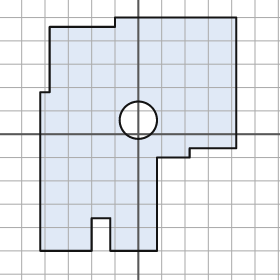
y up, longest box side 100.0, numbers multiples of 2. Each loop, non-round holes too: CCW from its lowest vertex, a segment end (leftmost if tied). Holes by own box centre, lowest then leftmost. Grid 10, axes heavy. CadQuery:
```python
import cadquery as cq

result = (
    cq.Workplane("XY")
    .moveTo(-42.0, -50.0)
    .lineTo(-20.0, -50.0)
    .lineTo(-20.0, -36.0)
    .lineTo(-12.0, -36.0)
    .lineTo(-12.0, -50.0)
    .lineTo(8.0, -50.0)
    .lineTo(8.0, -10.0)
    .lineTo(22.0, -10.0)
    .lineTo(22.0, -6.0)
    .lineTo(42.0, -6.0)
    .lineTo(42.0, 50.0)
    .lineTo(-10.0, 50.0)
    .lineTo(-10.0, 46.0)
    .lineTo(-38.0, 46.0)
    .lineTo(-38.0, 18.0)
    .lineTo(-42.0, 18.0)
    .close()
    .moveTo(0.0, 6.0)
    .circle(8.0)
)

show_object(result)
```